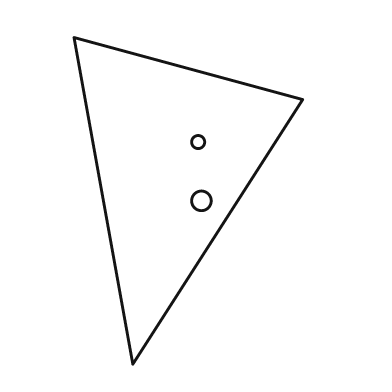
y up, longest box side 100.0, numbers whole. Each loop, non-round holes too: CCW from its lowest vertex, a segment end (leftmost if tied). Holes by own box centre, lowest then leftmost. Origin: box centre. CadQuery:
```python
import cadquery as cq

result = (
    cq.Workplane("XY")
    .moveTo(-17.0, -50.0)
    .lineTo(35.0, 31.0)
    .lineTo(-35.0, 50.0)
    .close()
    .moveTo(4.0, 0.0)
    .circle(3.0)
    .moveTo(3.0, 18.0)
    .circle(2.0)
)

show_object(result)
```